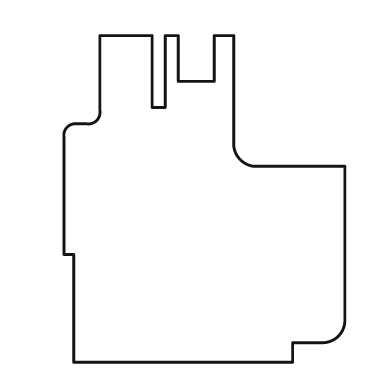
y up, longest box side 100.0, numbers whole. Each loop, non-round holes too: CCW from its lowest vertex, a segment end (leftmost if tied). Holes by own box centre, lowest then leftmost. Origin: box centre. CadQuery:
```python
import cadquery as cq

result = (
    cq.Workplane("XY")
    .moveTo(-40.0, -50.0)
    .lineTo(27.0, -50.0)
    .lineTo(27.0, -44.0)
    .lineTo(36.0, -44.0)
    .threePointArc((41.0, -42.0), (43.0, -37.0))
    .lineTo(43.0, 10.0)
    .lineTo(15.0, 10.0)
    .threePointArc((11.0, 12.0), (9.0, 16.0))
    .lineTo(9.0, 50.0)
    .lineTo(3.0, 50.0)
    .lineTo(3.0, 36.0)
    .lineTo(-8.0, 36.0)
    .lineTo(-8.0, 50.0)
    .lineTo(-12.0, 50.0)
    .lineTo(-12.0, 28.0)
    .lineTo(-16.0, 28.0)
    .lineTo(-16.0, 50.0)
    .lineTo(-32.0, 50.0)
    .lineTo(-32.0, 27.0)
    .threePointArc((-33.0, 24.0), (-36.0, 23.0))
    .lineTo(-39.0, 23.0)
    .threePointArc((-42.0, 22.0), (-43.0, 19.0))
    .lineTo(-43.0, -17.0)
    .lineTo(-40.0, -17.0)
    .close()
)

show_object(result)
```